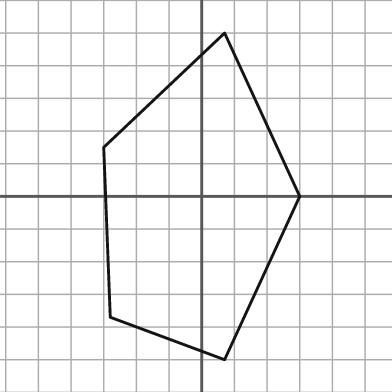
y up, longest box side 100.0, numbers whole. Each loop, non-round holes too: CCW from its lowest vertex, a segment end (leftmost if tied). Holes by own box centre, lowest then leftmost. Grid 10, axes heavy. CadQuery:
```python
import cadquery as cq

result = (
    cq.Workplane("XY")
    .moveTo(7.0, -50.0)
    .lineTo(30.0, 0.0)
    .lineTo(7.0, 50.0)
    .lineTo(-30.0, 15.0)
    .lineTo(-28.0, -37.0)
    .close()
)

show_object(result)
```